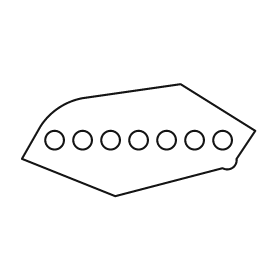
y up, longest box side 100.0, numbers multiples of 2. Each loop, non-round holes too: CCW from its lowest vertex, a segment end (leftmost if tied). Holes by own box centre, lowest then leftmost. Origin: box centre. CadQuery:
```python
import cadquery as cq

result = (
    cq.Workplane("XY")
    .moveTo(-10.0, -24.0)
    .lineTo(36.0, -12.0)
    .threePointArc((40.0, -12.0), (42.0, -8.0))
    .lineTo(50.0, 4.0)
    .lineTo(18.0, 24.0)
    .lineTo(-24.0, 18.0)
    .threePointArc((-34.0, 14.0), (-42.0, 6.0))
    .lineTo(-50.0, -8.0)
    .close()
    .moveTo(-36.0, 0.0)
    .circle(4.0)
    .moveTo(-24.0, 0.0)
    .circle(4.0)
    .moveTo(-12.0, 0.0)
    .circle(4.0)
    .moveTo(0.0, 0.0)
    .circle(4.0)
    .moveTo(12.0, 0.0)
    .circle(4.0)
    .moveTo(24.0, 0.0)
    .circle(4.0)
    .moveTo(36.0, 0.0)
    .circle(4.0)
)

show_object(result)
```